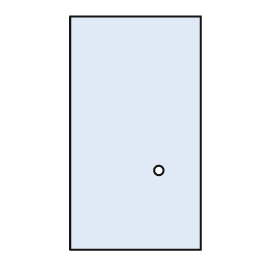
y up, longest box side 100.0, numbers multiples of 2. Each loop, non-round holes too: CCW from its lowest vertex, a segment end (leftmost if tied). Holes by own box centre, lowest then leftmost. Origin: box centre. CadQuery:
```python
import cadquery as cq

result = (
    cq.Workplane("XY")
    .moveTo(-28.0, -50.0)
    .lineTo(28.0, -50.0)
    .lineTo(28.0, 50.0)
    .lineTo(-28.0, 50.0)
    .close()
    .moveTo(10.0, -16.0)
    .circle(2.0)
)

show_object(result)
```